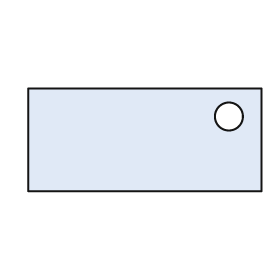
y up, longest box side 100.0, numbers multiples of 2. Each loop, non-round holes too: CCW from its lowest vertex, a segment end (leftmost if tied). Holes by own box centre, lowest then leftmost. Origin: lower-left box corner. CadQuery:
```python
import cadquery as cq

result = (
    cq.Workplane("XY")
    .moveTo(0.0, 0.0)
    .lineTo(100.0, 0.0)
    .lineTo(100.0, 44.0)
    .lineTo(0.0, 44.0)
    .close()
    .moveTo(86.0, 32.0)
    .circle(6.0)
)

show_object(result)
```